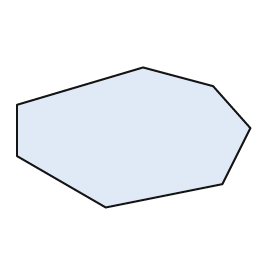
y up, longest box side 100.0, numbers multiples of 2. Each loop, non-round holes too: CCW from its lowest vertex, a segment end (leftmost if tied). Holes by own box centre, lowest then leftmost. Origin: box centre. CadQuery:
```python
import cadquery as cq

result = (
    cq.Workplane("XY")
    .moveTo(-12.0, -30.0)
    .lineTo(38.0, -20.0)
    .lineTo(50.0, 4.0)
    .lineTo(34.0, 22.0)
    .lineTo(4.0, 30.0)
    .lineTo(-50.0, 14.0)
    .lineTo(-50.0, -8.0)
    .close()
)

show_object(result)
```